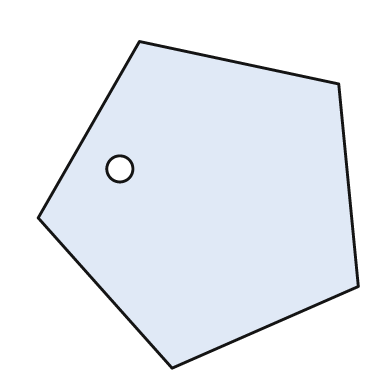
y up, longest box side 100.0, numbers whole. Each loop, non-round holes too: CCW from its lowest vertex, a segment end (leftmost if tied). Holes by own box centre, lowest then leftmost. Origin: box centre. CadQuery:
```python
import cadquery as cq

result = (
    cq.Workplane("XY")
    .moveTo(-8.0, -50.0)
    .lineTo(49.0, -25.0)
    .lineTo(43.0, 37.0)
    .lineTo(-18.0, 50.0)
    .lineTo(-49.0, -4.0)
    .close()
    .moveTo(-24.0, 11.0)
    .circle(4.0)
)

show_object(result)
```